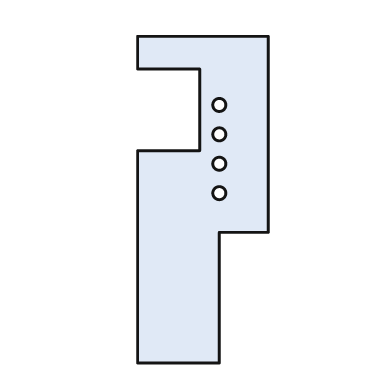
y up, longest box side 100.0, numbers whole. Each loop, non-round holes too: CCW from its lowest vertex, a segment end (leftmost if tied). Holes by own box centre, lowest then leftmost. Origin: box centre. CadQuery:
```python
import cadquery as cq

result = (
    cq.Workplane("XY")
    .moveTo(-20.0, -50.0)
    .lineTo(5.0, -50.0)
    .lineTo(5.0, -10.0)
    .lineTo(20.0, -10.0)
    .lineTo(20.0, 50.0)
    .lineTo(-20.0, 50.0)
    .lineTo(-20.0, 40.0)
    .lineTo(-1.0, 40.0)
    .lineTo(-1.0, 15.0)
    .lineTo(-20.0, 15.0)
    .close()
    .moveTo(5.0, 2.0)
    .circle(2.0)
    .moveTo(5.0, 11.0)
    .circle(2.0)
    .moveTo(5.0, 20.0)
    .circle(2.0)
    .moveTo(5.0, 29.0)
    .circle(2.0)
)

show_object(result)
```